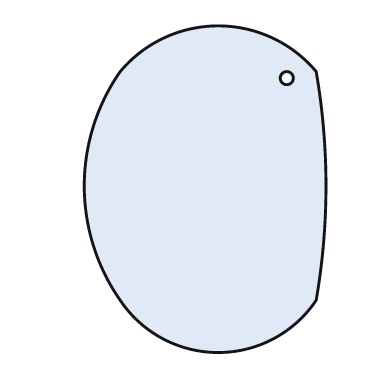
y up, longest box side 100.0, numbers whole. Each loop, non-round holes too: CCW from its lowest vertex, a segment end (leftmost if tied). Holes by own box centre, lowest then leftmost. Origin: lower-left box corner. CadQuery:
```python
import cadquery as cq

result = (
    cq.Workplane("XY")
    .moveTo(11.0, 16.0)
    .threePointArc((41.0, 0.0), (71.0, 16.0))
    .threePointArc((74.0, 51.0), (71.0, 86.0))
    .threePointArc((41.0, 100.0), (11.0, 86.0))
    .threePointArc((0.0, 51.0), (11.0, 16.0))
    .close()
    .moveTo(62.0, 84.0)
    .circle(2.0)
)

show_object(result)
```